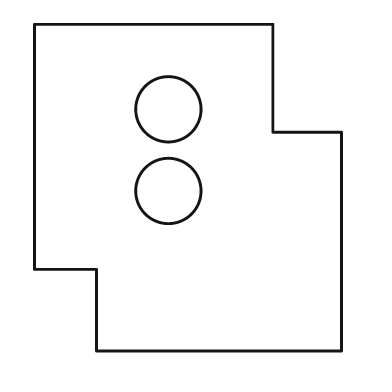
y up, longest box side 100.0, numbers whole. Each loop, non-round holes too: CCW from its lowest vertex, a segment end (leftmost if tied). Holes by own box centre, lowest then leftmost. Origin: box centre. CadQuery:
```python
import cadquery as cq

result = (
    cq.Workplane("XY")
    .moveTo(-28.0, -50.0)
    .lineTo(47.0, -50.0)
    .lineTo(47.0, 17.0)
    .lineTo(26.0, 17.0)
    .lineTo(26.0, 50.0)
    .lineTo(-47.0, 50.0)
    .lineTo(-47.0, -25.0)
    .lineTo(-28.0, -25.0)
    .close()
    .moveTo(-6.0, -1.0)
    .circle(10.0)
    .moveTo(-6.0, 24.0)
    .circle(10.0)
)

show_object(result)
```